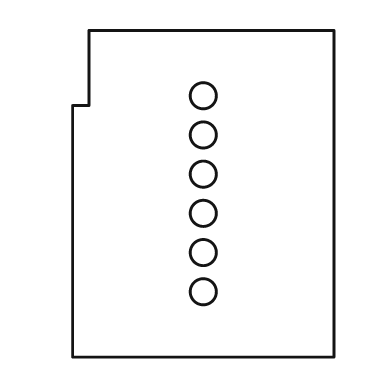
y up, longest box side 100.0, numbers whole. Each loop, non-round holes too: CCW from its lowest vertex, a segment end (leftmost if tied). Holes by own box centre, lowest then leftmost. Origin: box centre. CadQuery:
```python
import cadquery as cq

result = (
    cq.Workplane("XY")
    .moveTo(-40.0, -50.0)
    .lineTo(40.0, -50.0)
    .lineTo(40.0, 50.0)
    .lineTo(-35.0, 50.0)
    .lineTo(-35.0, 27.0)
    .lineTo(-40.0, 27.0)
    .close()
    .moveTo(0.0, -30.0)
    .circle(4.0)
    .moveTo(0.0, -18.0)
    .circle(4.0)
    .moveTo(0.0, -6.0)
    .circle(4.0)
    .moveTo(0.0, 6.0)
    .circle(4.0)
    .moveTo(0.0, 18.0)
    .circle(4.0)
    .moveTo(0.0, 30.0)
    .circle(4.0)
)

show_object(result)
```